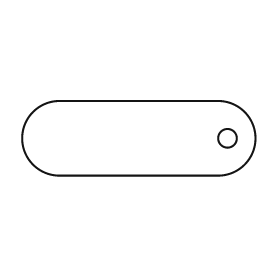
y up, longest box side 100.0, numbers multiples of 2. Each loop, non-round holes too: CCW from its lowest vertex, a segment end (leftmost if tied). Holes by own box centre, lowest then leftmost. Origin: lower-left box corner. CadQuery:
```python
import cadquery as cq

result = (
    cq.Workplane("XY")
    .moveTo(16.0, 0.0)
    .lineTo(84.0, 0.0)
    .threePointArc((100.0, 16.0), (84.0, 32.0))
    .lineTo(16.0, 32.0)
    .threePointArc((0.0, 16.0), (16.0, 0.0))
    .close()
    .moveTo(88.0, 16.0)
    .circle(4.0)
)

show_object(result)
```